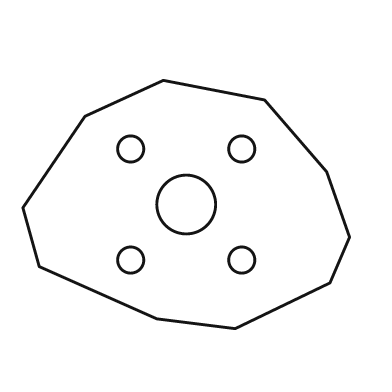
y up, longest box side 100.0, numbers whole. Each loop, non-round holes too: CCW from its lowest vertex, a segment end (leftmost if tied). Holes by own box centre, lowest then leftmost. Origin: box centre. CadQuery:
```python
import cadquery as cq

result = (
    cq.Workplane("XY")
    .moveTo(15.0, -38.0)
    .lineTo(44.0, -24.0)
    .lineTo(50.0, -10.0)
    .lineTo(43.0, 10.0)
    .lineTo(24.0, 32.0)
    .lineTo(-7.0, 38.0)
    .lineTo(-31.0, 27.0)
    .lineTo(-50.0, -1.0)
    .lineTo(-45.0, -19.0)
    .lineTo(-9.0, -35.0)
    .close()
    .moveTo(-17.0, -17.0)
    .circle(4.0)
    .moveTo(17.0, -17.0)
    .circle(4.0)
    .moveTo(0.0, 0.0)
    .circle(9.0)
    .moveTo(-17.0, 17.0)
    .circle(4.0)
    .moveTo(17.0, 17.0)
    .circle(4.0)
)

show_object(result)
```